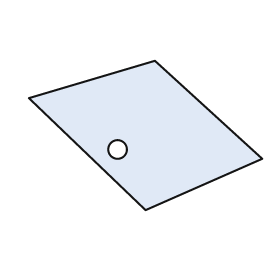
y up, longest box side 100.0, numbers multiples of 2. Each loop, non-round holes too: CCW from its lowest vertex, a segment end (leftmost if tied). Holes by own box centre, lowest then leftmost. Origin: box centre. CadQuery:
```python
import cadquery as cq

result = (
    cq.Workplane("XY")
    .moveTo(0.0, -32.0)
    .lineTo(50.0, -10.0)
    .lineTo(4.0, 32.0)
    .lineTo(-50.0, 16.0)
    .close()
    .moveTo(-12.0, -6.0)
    .circle(4.0)
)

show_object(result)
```